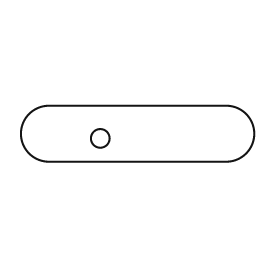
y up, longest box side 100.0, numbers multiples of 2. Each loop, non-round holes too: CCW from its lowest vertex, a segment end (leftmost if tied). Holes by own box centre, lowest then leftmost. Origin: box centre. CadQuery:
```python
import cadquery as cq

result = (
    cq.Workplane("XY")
    .moveTo(-38.0, -12.0)
    .lineTo(38.0, -12.0)
    .threePointArc((50.0, 0.0), (38.0, 12.0))
    .lineTo(-38.0, 12.0)
    .threePointArc((-50.0, 0.0), (-38.0, -12.0))
    .close()
    .moveTo(-16.0, -2.0)
    .circle(4.0)
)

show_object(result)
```